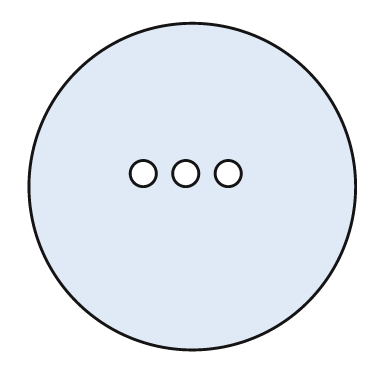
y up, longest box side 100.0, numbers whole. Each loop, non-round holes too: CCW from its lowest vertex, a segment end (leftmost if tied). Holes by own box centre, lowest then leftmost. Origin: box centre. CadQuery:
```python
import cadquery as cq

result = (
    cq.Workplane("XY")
    .moveTo(0.0, 0.0)
    .circle(50.0)
    .moveTo(-15.0, 4.0)
    .circle(4.0)
    .moveTo(-2.0, 4.0)
    .circle(4.0)
    .moveTo(11.0, 4.0)
    .circle(4.0)
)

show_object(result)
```